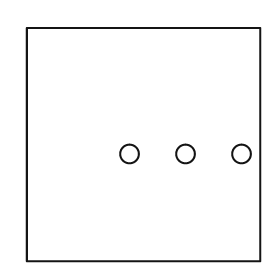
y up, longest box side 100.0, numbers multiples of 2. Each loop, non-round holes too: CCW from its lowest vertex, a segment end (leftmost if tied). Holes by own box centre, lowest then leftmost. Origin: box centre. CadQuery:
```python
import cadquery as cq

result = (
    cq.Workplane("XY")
    .moveTo(-50.0, -50.0)
    .lineTo(50.0, -50.0)
    .lineTo(50.0, 50.0)
    .lineTo(-50.0, 50.0)
    .close()
    .moveTo(-6.0, -4.0)
    .circle(4.0)
    .moveTo(18.0, -4.0)
    .circle(4.0)
    .moveTo(42.0, -4.0)
    .circle(4.0)
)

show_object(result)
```